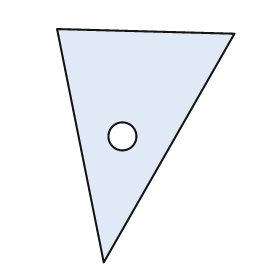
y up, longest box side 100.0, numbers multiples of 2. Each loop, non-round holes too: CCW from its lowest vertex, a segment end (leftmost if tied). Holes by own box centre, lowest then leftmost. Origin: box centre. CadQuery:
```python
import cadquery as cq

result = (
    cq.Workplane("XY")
    .moveTo(-18.0, -50.0)
    .lineTo(38.0, 48.0)
    .lineTo(-38.0, 50.0)
    .close()
    .moveTo(-10.0, 4.0)
    .circle(6.0)
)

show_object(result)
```